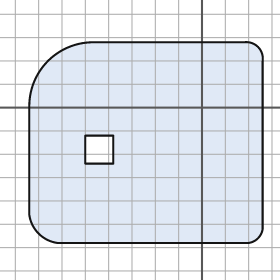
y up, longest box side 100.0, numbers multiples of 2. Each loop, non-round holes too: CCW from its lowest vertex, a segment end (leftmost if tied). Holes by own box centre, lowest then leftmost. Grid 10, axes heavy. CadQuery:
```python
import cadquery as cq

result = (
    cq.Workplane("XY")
    .moveTo(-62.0, -58.0)
    .lineTo(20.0, -58.0)
    .threePointArc((24.0, -56.0), (26.0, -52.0))
    .lineTo(26.0, 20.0)
    .threePointArc((24.0, 26.0), (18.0, 28.0))
    .lineTo(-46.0, 28.0)
    .threePointArc((-66.0, 20.0), (-74.0, 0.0))
    .lineTo(-74.0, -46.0)
    .threePointArc((-70.0, -54.0), (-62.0, -58.0))
    .close()
    .moveTo(-50.0, -24.0)
    .lineTo(-38.0, -24.0)
    .lineTo(-38.0, -12.0)
    .lineTo(-50.0, -12.0)
    .close()
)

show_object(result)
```